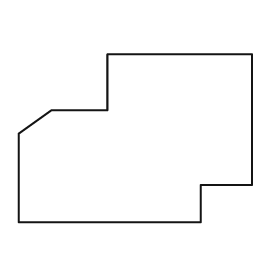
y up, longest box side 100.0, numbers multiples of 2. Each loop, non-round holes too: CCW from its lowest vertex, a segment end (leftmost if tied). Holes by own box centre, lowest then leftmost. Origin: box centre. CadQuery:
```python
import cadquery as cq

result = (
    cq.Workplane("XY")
    .moveTo(-50.0, -36.0)
    .lineTo(28.0, -36.0)
    .lineTo(28.0, -20.0)
    .lineTo(50.0, -20.0)
    .lineTo(50.0, 36.0)
    .lineTo(-12.0, 36.0)
    .lineTo(-12.0, 12.0)
    .lineTo(-36.0, 12.0)
    .lineTo(-50.0, 2.0)
    .close()
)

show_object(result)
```